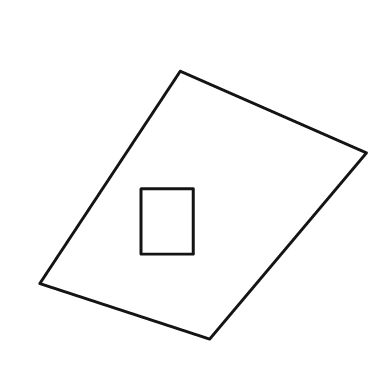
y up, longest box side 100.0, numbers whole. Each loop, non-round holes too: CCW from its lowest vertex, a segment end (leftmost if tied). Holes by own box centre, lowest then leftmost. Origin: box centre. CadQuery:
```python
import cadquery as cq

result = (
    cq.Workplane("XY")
    .moveTo(2.0, -41.0)
    .lineTo(50.0, 16.0)
    .lineTo(-7.0, 41.0)
    .lineTo(-50.0, -24.0)
    .close()
    .moveTo(-19.0, -15.0)
    .lineTo(-3.0, -15.0)
    .lineTo(-3.0, 5.0)
    .lineTo(-19.0, 5.0)
    .close()
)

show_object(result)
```